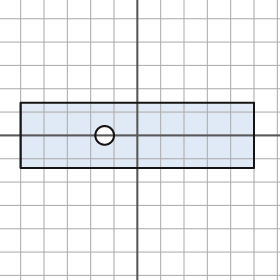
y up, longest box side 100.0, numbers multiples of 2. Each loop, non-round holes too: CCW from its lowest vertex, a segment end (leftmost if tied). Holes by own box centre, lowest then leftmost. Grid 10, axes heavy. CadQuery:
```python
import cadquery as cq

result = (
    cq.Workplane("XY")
    .moveTo(-50.0, -14.0)
    .lineTo(50.0, -14.0)
    .lineTo(50.0, 14.0)
    .lineTo(-50.0, 14.0)
    .close()
    .moveTo(-14.0, 0.0)
    .circle(4.0)
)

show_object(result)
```